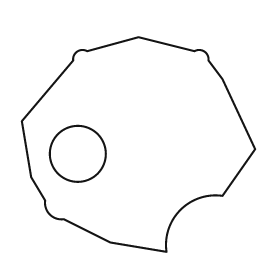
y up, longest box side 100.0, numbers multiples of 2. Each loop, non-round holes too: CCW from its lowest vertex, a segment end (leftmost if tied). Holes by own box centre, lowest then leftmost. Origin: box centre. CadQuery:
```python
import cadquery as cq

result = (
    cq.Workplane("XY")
    .moveTo(12.0, -46.0)
    .threePointArc((18.0, -28.0), (36.0, -22.0))
    .lineTo(50.0, -2.0)
    .lineTo(36.0, 28.0)
    .lineTo(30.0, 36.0)
    .threePointArc((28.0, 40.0), (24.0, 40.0))
    .lineTo(0.0, 46.0)
    .lineTo(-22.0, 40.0)
    .threePointArc((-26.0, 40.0), (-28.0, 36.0))
    .lineTo(-50.0, 10.0)
    .lineTo(-46.0, -14.0)
    .lineTo(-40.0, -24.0)
    .threePointArc((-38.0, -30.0), (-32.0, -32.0))
    .lineTo(-12.0, -42.0)
    .close()
    .moveTo(-26.0, -4.0)
    .circle(12.0)
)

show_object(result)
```